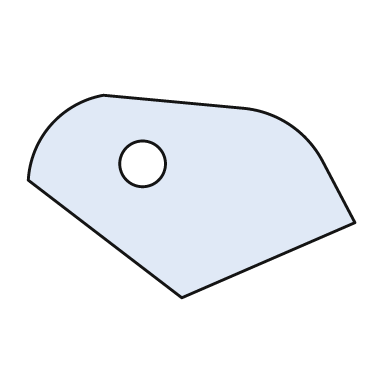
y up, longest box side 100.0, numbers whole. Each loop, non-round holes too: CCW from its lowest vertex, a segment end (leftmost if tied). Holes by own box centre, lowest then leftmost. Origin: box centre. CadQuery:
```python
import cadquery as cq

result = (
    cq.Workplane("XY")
    .moveTo(-3.0, -31.0)
    .lineTo(50.0, -8.0)
    .lineTo(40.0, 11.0)
    .threePointArc((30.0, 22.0), (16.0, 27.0))
    .lineTo(-27.0, 31.0)
    .threePointArc((-43.0, 22.0), (-50.0, 5.0))
    .close()
    .moveTo(-15.0, 10.0)
    .circle(7.0)
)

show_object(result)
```